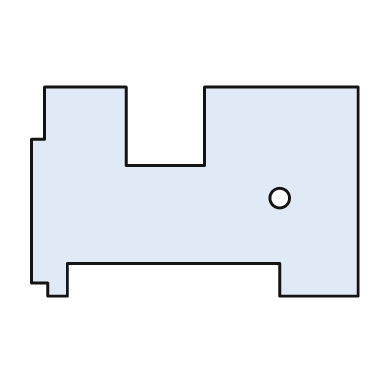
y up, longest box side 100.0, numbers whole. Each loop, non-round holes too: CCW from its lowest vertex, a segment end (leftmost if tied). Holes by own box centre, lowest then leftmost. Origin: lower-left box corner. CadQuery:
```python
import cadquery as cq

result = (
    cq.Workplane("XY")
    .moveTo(5.0, 0.0)
    .lineTo(11.0, 0.0)
    .lineTo(11.0, 10.0)
    .lineTo(76.0, 10.0)
    .lineTo(76.0, 0.0)
    .lineTo(100.0, 0.0)
    .lineTo(100.0, 64.0)
    .lineTo(53.0, 64.0)
    .lineTo(53.0, 40.0)
    .lineTo(29.0, 40.0)
    .lineTo(29.0, 64.0)
    .lineTo(4.0, 64.0)
    .lineTo(4.0, 48.0)
    .lineTo(0.0, 48.0)
    .lineTo(0.0, 4.0)
    .lineTo(5.0, 4.0)
    .close()
    .moveTo(76.0, 30.0)
    .circle(3.0)
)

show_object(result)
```